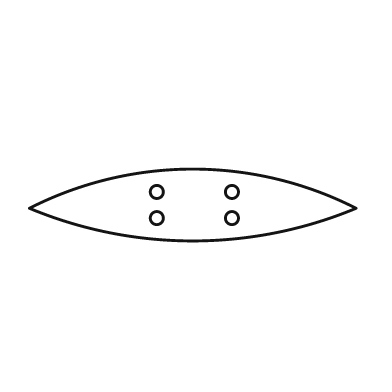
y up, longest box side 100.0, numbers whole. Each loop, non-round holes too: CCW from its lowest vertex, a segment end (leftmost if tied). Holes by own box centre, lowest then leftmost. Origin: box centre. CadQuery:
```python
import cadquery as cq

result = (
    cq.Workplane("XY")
    .moveTo(-50.0, -1.0)
    .threePointArc((0.0, -11.0), (50.0, -1.0))
    .threePointArc((0.0, 11.0), (-50.0, -1.0))
    .close()
    .moveTo(-11.0, -4.0)
    .circle(2.0)
    .moveTo(12.0, -4.0)
    .circle(2.0)
    .moveTo(-11.0, 4.0)
    .circle(2.0)
    .moveTo(12.0, 4.0)
    .circle(2.0)
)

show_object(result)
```